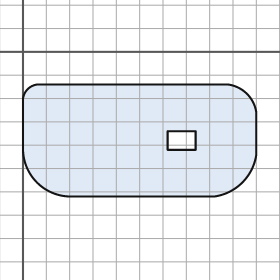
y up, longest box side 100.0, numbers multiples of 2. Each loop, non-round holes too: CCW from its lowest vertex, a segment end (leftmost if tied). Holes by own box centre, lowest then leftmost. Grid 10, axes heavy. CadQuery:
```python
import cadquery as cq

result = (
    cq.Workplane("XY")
    .moveTo(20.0, -62.0)
    .lineTo(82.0, -62.0)
    .threePointArc((94.0, -56.0), (100.0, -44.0))
    .lineTo(100.0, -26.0)
    .threePointArc((96.0, -18.0), (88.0, -14.0))
    .lineTo(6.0, -14.0)
    .threePointArc((2.0, -16.0), (0.0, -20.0))
    .lineTo(0.0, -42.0)
    .threePointArc((6.0, -56.0), (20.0, -62.0))
    .close()
    .moveTo(62.0, -42.0)
    .lineTo(74.0, -42.0)
    .lineTo(74.0, -34.0)
    .lineTo(62.0, -34.0)
    .close()
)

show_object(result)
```